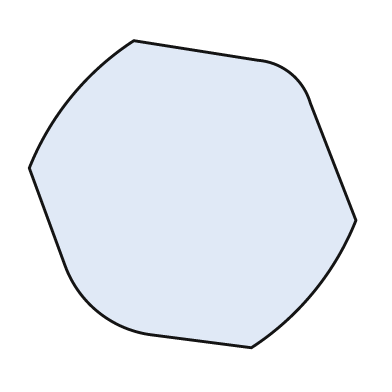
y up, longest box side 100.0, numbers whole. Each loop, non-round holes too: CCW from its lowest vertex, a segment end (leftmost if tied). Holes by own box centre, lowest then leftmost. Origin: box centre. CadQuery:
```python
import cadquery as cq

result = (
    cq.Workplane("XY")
    .moveTo(18.0, -47.0)
    .threePointArc((37.0, -30.0), (50.0, -8.0))
    .lineTo(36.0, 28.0)
    .threePointArc((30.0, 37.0), (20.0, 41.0))
    .lineTo(-18.0, 47.0)
    .threePointArc((-37.0, 30.0), (-50.0, 8.0))
    .lineTo(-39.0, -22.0)
    .threePointArc((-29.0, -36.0), (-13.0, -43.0))
    .close()
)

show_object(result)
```